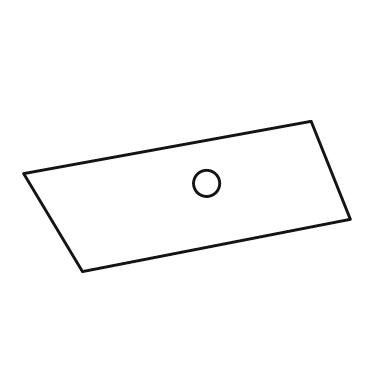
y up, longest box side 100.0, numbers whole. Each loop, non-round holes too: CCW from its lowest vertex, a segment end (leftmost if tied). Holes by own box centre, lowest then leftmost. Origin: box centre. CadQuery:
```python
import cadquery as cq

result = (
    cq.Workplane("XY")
    .moveTo(-32.0, -23.0)
    .lineTo(50.0, -7.0)
    .lineTo(38.0, 23.0)
    .lineTo(-50.0, 7.0)
    .close()
    .moveTo(6.0, 4.0)
    .circle(4.0)
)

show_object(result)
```